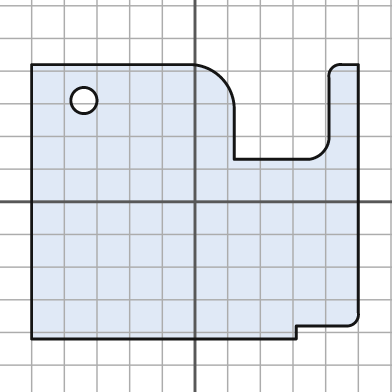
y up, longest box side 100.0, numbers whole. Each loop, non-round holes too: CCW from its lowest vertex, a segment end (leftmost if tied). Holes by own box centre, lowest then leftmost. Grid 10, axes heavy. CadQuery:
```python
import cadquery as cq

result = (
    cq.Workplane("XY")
    .moveTo(-50.0, -42.0)
    .lineTo(31.0, -42.0)
    .lineTo(31.0, -38.0)
    .lineTo(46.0, -38.0)
    .threePointArc((49.0, -37.0), (50.0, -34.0))
    .lineTo(50.0, 42.0)
    .lineTo(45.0, 42.0)
    .threePointArc((42.0, 41.0), (41.0, 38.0))
    .lineTo(41.0, 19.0)
    .threePointArc((39.0, 15.0), (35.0, 13.0))
    .lineTo(12.0, 13.0)
    .lineTo(12.0, 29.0)
    .threePointArc((8.0, 38.0), (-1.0, 42.0))
    .lineTo(-50.0, 42.0)
    .close()
    .moveTo(-34.0, 31.0)
    .circle(4.0)
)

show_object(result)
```